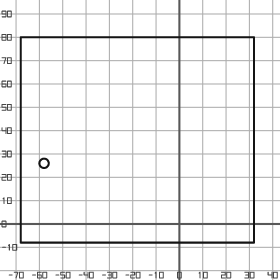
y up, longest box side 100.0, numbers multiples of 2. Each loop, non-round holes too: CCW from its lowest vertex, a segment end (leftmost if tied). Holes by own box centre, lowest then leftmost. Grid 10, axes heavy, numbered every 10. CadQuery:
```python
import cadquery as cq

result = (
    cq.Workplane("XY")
    .moveTo(-68.0, -8.0)
    .lineTo(32.0, -8.0)
    .lineTo(32.0, 80.0)
    .lineTo(-68.0, 80.0)
    .close()
    .moveTo(-58.0, 26.0)
    .circle(2.0)
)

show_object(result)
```